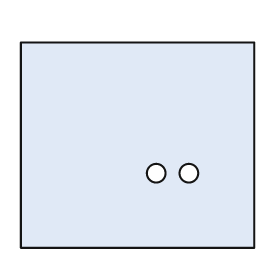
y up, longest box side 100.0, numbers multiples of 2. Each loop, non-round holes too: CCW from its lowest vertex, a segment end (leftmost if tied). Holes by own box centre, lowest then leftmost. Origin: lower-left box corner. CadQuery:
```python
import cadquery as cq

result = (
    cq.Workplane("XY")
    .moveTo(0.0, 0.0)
    .lineTo(100.0, 0.0)
    .lineTo(100.0, 88.0)
    .lineTo(0.0, 88.0)
    .close()
    .moveTo(58.0, 32.0)
    .circle(4.0)
    .moveTo(72.0, 32.0)
    .circle(4.0)
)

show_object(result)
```